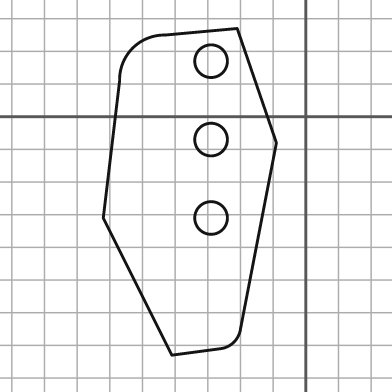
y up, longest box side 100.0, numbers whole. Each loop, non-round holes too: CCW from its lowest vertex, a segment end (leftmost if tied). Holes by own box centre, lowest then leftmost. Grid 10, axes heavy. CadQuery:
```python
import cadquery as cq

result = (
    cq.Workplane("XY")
    .moveTo(-41.0, -73.0)
    .lineTo(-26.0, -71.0)
    .threePointArc((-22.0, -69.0), (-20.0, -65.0))
    .lineTo(-9.0, -8.0)
    .lineTo(-21.0, 27.0)
    .lineTo(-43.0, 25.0)
    .threePointArc((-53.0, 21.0), (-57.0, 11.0))
    .lineTo(-62.0, -31.0)
    .close()
    .moveTo(-29.0, -31.0)
    .circle(5.0)
    .moveTo(-29.0, -7.0)
    .circle(5.0)
    .moveTo(-29.0, 17.0)
    .circle(5.0)
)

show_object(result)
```